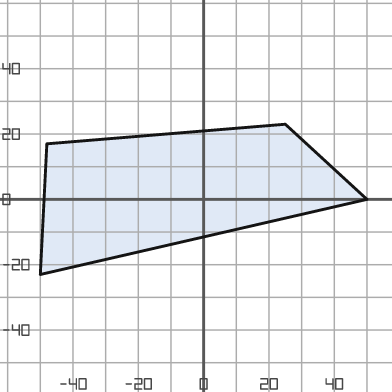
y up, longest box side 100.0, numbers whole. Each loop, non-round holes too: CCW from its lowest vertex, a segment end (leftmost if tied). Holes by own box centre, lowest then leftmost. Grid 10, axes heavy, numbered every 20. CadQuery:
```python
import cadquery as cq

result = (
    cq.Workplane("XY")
    .moveTo(-50.0, -23.0)
    .lineTo(50.0, 0.0)
    .lineTo(25.0, 23.0)
    .lineTo(-48.0, 17.0)
    .close()
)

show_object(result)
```